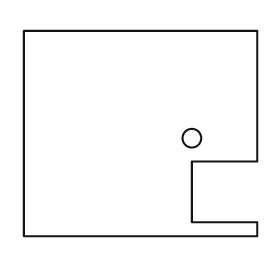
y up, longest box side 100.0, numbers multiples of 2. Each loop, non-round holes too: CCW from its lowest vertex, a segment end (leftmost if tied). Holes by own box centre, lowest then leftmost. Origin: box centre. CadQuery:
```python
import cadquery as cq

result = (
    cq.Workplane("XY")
    .moveTo(-50.0, -44.0)
    .lineTo(50.0, -44.0)
    .lineTo(50.0, -38.0)
    .lineTo(22.0, -38.0)
    .lineTo(22.0, -12.0)
    .lineTo(50.0, -12.0)
    .lineTo(50.0, 44.0)
    .lineTo(-50.0, 44.0)
    .close()
    .moveTo(22.0, -2.0)
    .circle(4.0)
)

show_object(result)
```